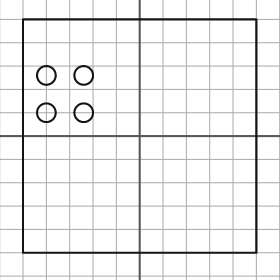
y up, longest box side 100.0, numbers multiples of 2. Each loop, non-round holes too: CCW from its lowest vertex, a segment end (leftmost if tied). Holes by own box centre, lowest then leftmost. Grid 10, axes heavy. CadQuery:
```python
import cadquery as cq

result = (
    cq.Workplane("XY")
    .moveTo(-50.0, -50.0)
    .lineTo(50.0, -50.0)
    .lineTo(50.0, 50.0)
    .lineTo(-50.0, 50.0)
    .close()
    .moveTo(-40.0, 10.0)
    .circle(4.0)
    .moveTo(-24.0, 10.0)
    .circle(4.0)
    .moveTo(-40.0, 26.0)
    .circle(4.0)
    .moveTo(-24.0, 26.0)
    .circle(4.0)
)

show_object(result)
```